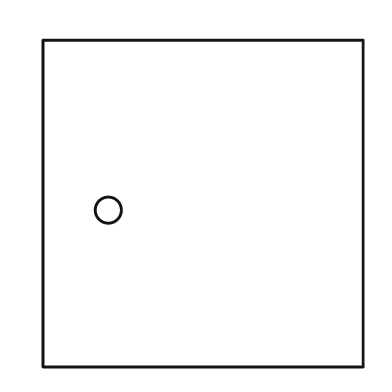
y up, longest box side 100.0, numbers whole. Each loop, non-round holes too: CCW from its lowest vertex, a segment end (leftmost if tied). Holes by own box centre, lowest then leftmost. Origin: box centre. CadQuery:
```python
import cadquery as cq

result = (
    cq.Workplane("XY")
    .moveTo(-49.0, -50.0)
    .lineTo(49.0, -50.0)
    .lineTo(49.0, 50.0)
    .lineTo(-49.0, 50.0)
    .close()
    .moveTo(-29.0, -2.0)
    .circle(4.0)
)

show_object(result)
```